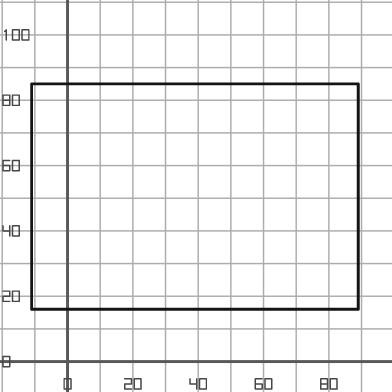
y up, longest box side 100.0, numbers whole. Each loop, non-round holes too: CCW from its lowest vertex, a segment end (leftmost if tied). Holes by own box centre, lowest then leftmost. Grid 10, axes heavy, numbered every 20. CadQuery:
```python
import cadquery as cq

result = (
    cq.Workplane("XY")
    .moveTo(-11.0, 16.0)
    .lineTo(89.0, 16.0)
    .lineTo(89.0, 85.0)
    .lineTo(-11.0, 85.0)
    .close()
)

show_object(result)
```